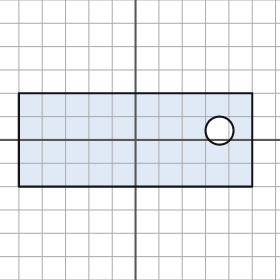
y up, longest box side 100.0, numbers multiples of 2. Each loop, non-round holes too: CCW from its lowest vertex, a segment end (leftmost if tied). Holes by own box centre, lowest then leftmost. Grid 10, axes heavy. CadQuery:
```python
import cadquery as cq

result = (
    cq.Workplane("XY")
    .moveTo(-50.0, -20.0)
    .lineTo(50.0, -20.0)
    .lineTo(50.0, 20.0)
    .lineTo(-50.0, 20.0)
    .close()
    .moveTo(36.0, 4.0)
    .circle(6.0)
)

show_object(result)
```